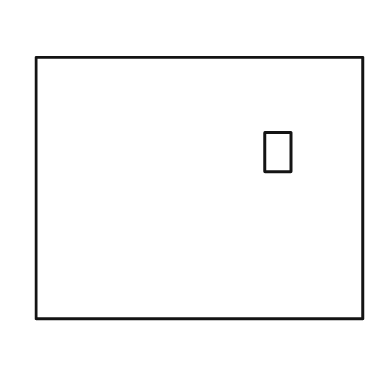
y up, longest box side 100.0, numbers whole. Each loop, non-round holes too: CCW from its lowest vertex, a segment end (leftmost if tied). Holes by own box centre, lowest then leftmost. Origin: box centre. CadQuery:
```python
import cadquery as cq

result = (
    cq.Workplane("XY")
    .moveTo(-50.0, -40.0)
    .lineTo(50.0, -40.0)
    .lineTo(50.0, 40.0)
    .lineTo(-50.0, 40.0)
    .close()
    .moveTo(20.0, 5.0)
    .lineTo(28.0, 5.0)
    .lineTo(28.0, 17.0)
    .lineTo(20.0, 17.0)
    .close()
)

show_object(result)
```